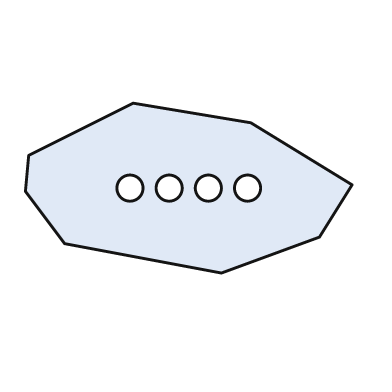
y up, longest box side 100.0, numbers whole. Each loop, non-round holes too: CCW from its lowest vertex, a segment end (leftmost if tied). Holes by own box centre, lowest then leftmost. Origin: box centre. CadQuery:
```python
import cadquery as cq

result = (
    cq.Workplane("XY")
    .moveTo(10.0, -26.0)
    .lineTo(40.0, -15.0)
    .lineTo(50.0, 1.0)
    .lineTo(19.0, 20.0)
    .lineTo(-17.0, 26.0)
    .lineTo(-49.0, 10.0)
    .lineTo(-50.0, -1.0)
    .lineTo(-38.0, -17.0)
    .close()
    .moveTo(-18.0, 0.0)
    .circle(4.0)
    .moveTo(-6.0, 0.0)
    .circle(4.0)
    .moveTo(6.0, 0.0)
    .circle(4.0)
    .moveTo(18.0, 0.0)
    .circle(4.0)
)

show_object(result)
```